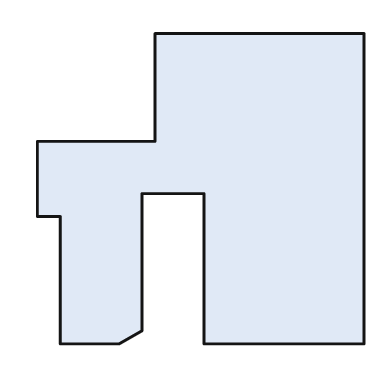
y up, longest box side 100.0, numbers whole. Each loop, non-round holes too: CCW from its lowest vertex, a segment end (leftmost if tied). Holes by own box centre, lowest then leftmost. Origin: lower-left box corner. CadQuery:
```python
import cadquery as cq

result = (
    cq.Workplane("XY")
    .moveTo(7.0, 0.0)
    .lineTo(25.0, 0.0)
    .lineTo(32.0, 4.0)
    .lineTo(32.0, 46.0)
    .lineTo(51.0, 46.0)
    .lineTo(51.0, 0.0)
    .lineTo(100.0, 0.0)
    .lineTo(100.0, 95.0)
    .lineTo(36.0, 95.0)
    .lineTo(36.0, 62.0)
    .lineTo(0.0, 62.0)
    .lineTo(0.0, 39.0)
    .lineTo(7.0, 39.0)
    .close()
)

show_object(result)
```